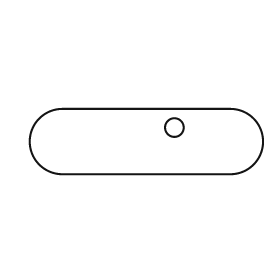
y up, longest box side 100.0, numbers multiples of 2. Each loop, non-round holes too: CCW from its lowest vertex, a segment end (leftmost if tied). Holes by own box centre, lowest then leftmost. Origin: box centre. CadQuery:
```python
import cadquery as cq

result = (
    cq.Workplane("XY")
    .moveTo(-36.0, -14.0)
    .lineTo(36.0, -14.0)
    .threePointArc((50.0, 0.0), (36.0, 14.0))
    .lineTo(-36.0, 14.0)
    .threePointArc((-50.0, 0.0), (-36.0, -14.0))
    .close()
    .moveTo(12.0, 6.0)
    .circle(4.0)
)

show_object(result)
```